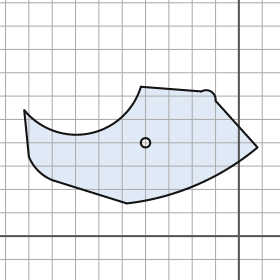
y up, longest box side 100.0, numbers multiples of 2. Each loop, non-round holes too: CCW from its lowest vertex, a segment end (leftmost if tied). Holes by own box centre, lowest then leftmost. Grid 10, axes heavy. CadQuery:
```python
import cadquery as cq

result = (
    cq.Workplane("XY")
    .moveTo(-48.0, 14.0)
    .threePointArc((-18.0, 22.0), (8.0, 38.0))
    .lineTo(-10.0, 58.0)
    .threePointArc((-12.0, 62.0), (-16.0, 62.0))
    .lineTo(-42.0, 64.0)
    .threePointArc((-64.0, 44.0), (-92.0, 54.0))
    .lineTo(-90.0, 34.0)
    .threePointArc((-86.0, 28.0), (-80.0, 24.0))
    .close()
    .moveTo(-40.0, 40.0)
    .circle(2.0)
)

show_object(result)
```